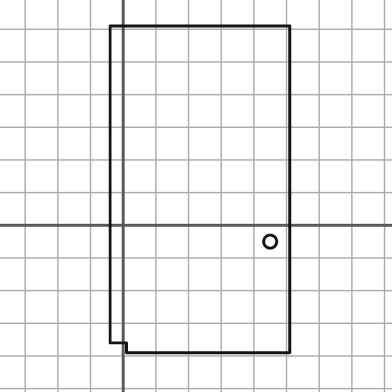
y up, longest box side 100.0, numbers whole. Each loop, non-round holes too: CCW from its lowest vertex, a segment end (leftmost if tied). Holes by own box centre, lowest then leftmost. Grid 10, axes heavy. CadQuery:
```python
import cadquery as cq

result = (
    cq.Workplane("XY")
    .moveTo(1.0, -39.0)
    .lineTo(51.0, -39.0)
    .lineTo(51.0, 61.0)
    .lineTo(-4.0, 61.0)
    .lineTo(-4.0, -36.0)
    .lineTo(1.0, -36.0)
    .close()
    .moveTo(45.0, -5.0)
    .circle(2.0)
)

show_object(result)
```